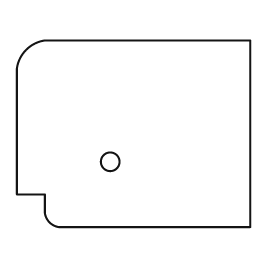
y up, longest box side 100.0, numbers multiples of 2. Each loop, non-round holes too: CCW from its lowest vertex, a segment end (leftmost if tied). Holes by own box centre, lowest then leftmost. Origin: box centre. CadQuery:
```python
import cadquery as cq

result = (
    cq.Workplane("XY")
    .moveTo(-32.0, -40.0)
    .lineTo(50.0, -40.0)
    .lineTo(50.0, 40.0)
    .lineTo(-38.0, 40.0)
    .threePointArc((-46.0, 36.0), (-50.0, 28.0))
    .lineTo(-50.0, -26.0)
    .lineTo(-38.0, -26.0)
    .lineTo(-38.0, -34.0)
    .threePointArc((-36.0, -38.0), (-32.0, -40.0))
    .close()
    .moveTo(-10.0, -12.0)
    .circle(4.0)
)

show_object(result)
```